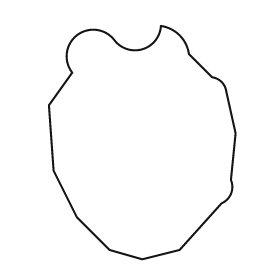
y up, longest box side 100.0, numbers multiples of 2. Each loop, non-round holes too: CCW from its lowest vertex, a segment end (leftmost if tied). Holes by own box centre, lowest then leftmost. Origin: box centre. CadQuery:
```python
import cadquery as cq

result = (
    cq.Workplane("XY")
    .moveTo(0.0, -50.0)
    .lineTo(16.0, -46.0)
    .lineTo(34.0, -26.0)
    .threePointArc((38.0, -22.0), (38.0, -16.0))
    .lineTo(40.0, 4.0)
    .lineTo(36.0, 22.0)
    .threePointArc((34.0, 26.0), (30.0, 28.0))
    .lineTo(20.0, 38.0)
    .threePointArc((16.0, 46.0), (8.0, 50.0))
    .threePointArc((0.0, 40.0), (-12.0, 44.0))
    .threePointArc((-28.0, 46.0), (-30.0, 30.0))
    .lineTo(-40.0, 16.0)
    .lineTo(-38.0, -12.0)
    .lineTo(-28.0, -32.0)
    .lineTo(-14.0, -46.0)
    .close()
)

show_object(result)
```